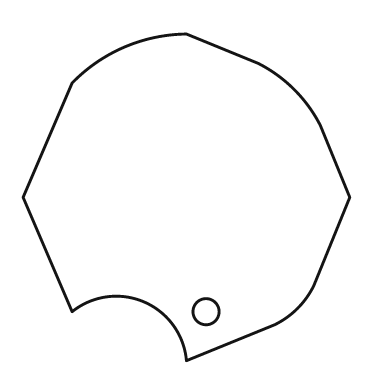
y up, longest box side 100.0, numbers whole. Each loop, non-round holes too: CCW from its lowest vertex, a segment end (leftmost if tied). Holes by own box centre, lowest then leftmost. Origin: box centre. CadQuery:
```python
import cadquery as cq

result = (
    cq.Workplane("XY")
    .moveTo(0.0, -50.0)
    .lineTo(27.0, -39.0)
    .threePointArc((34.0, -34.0), (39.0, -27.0))
    .lineTo(50.0, 0.0)
    .lineTo(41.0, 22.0)
    .threePointArc((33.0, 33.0), (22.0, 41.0))
    .lineTo(0.0, 50.0)
    .threePointArc((-19.0, 46.0), (-35.0, 35.0))
    .lineTo(-50.0, 0.0)
    .lineTo(-35.0, -35.0)
    .threePointArc((-13.0, -32.0), (0.0, -50.0))
    .close()
    .moveTo(6.0, -35.0)
    .circle(4.0)
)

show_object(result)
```